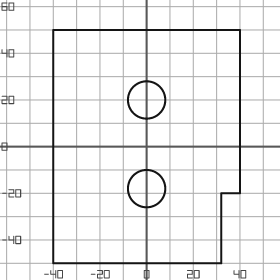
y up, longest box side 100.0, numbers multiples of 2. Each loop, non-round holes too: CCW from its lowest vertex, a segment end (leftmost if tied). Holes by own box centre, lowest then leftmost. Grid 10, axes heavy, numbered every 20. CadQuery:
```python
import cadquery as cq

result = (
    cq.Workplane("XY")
    .moveTo(-40.0, -50.0)
    .lineTo(32.0, -50.0)
    .lineTo(32.0, -20.0)
    .lineTo(40.0, -20.0)
    .lineTo(40.0, 50.0)
    .lineTo(-40.0, 50.0)
    .close()
    .moveTo(0.0, -18.0)
    .circle(8.0)
    .moveTo(0.0, 20.0)
    .circle(8.0)
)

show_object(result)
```